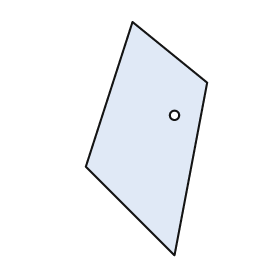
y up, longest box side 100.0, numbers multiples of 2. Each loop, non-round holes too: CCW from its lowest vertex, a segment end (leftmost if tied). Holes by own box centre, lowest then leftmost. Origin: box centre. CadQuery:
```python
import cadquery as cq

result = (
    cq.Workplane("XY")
    .moveTo(12.0, -50.0)
    .lineTo(26.0, 24.0)
    .lineTo(-6.0, 50.0)
    .lineTo(-26.0, -12.0)
    .close()
    .moveTo(12.0, 10.0)
    .circle(2.0)
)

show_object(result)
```